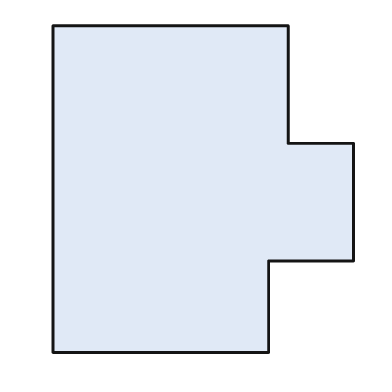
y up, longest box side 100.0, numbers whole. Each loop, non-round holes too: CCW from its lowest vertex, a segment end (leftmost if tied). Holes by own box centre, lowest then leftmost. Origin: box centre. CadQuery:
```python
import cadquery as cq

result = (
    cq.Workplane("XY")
    .moveTo(-46.0, -50.0)
    .lineTo(20.0, -50.0)
    .lineTo(20.0, -22.0)
    .lineTo(46.0, -22.0)
    .lineTo(46.0, 14.0)
    .lineTo(26.0, 14.0)
    .lineTo(26.0, 50.0)
    .lineTo(-46.0, 50.0)
    .close()
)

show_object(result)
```